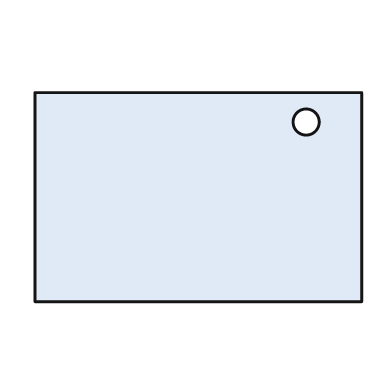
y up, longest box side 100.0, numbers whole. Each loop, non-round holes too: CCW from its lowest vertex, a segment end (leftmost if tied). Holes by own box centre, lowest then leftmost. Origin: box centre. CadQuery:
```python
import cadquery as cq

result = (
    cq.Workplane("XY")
    .moveTo(-50.0, -32.0)
    .lineTo(50.0, -32.0)
    .lineTo(50.0, 32.0)
    .lineTo(-50.0, 32.0)
    .close()
    .moveTo(33.0, 23.0)
    .circle(4.0)
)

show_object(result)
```